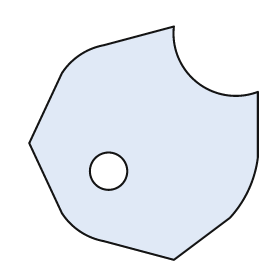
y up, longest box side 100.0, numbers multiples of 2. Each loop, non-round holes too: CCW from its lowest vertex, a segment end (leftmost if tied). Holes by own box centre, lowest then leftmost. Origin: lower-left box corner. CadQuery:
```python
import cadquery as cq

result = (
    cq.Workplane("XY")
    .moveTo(62.0, 0.0)
    .lineTo(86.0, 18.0)
    .threePointArc((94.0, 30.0), (98.0, 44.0))
    .lineTo(98.0, 72.0)
    .threePointArc((72.0, 76.0), (62.0, 100.0))
    .lineTo(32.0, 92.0)
    .threePointArc((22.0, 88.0), (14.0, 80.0))
    .lineTo(0.0, 50.0)
    .lineTo(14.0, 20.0)
    .threePointArc((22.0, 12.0), (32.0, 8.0))
    .close()
    .moveTo(34.0, 38.0)
    .circle(8.0)
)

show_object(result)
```